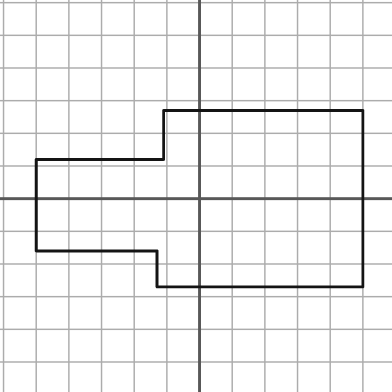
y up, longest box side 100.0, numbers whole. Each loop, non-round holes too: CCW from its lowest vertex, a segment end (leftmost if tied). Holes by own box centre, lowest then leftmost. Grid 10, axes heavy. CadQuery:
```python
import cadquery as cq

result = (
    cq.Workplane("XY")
    .moveTo(-13.0, -27.0)
    .lineTo(50.0, -27.0)
    .lineTo(50.0, 27.0)
    .lineTo(-11.0, 27.0)
    .lineTo(-11.0, 12.0)
    .lineTo(-50.0, 12.0)
    .lineTo(-50.0, -16.0)
    .lineTo(-13.0, -16.0)
    .close()
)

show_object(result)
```